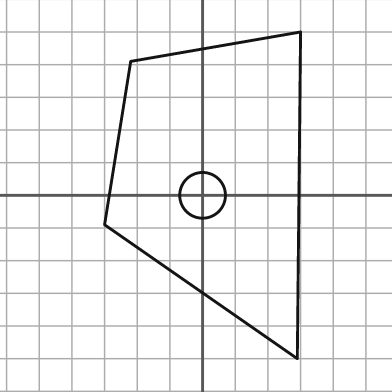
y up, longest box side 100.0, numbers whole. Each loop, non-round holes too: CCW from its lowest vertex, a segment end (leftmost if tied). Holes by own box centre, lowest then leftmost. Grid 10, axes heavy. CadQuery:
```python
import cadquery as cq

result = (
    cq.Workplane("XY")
    .moveTo(29.0, -50.0)
    .lineTo(30.0, 50.0)
    .lineTo(-22.0, 41.0)
    .lineTo(-30.0, -9.0)
    .close()
    .moveTo(0.0, 0.0)
    .circle(7.0)
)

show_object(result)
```